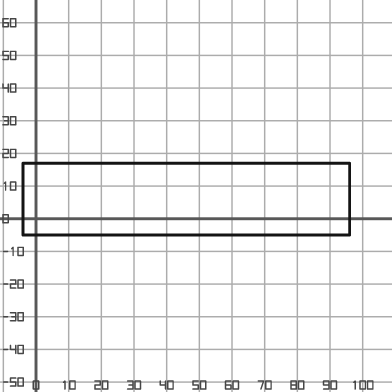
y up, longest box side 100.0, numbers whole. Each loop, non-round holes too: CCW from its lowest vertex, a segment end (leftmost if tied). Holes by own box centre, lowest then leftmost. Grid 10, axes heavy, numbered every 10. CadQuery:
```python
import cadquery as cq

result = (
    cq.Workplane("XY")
    .moveTo(-4.0, -5.0)
    .lineTo(96.0, -5.0)
    .lineTo(96.0, 17.0)
    .lineTo(-4.0, 17.0)
    .close()
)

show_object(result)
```